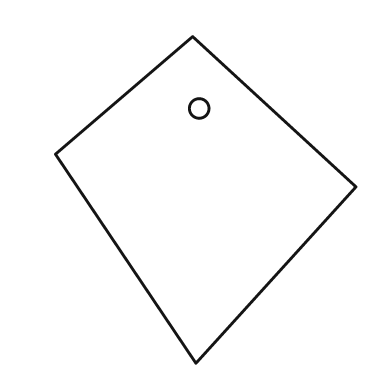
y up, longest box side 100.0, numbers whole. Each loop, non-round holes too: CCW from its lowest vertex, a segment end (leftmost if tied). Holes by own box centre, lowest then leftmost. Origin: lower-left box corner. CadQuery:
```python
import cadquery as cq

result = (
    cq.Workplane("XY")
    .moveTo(43.0, 0.0)
    .lineTo(92.0, 54.0)
    .lineTo(42.0, 100.0)
    .lineTo(0.0, 64.0)
    .close()
    .moveTo(44.0, 78.0)
    .circle(3.0)
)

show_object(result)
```